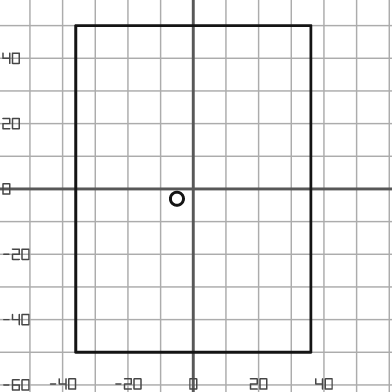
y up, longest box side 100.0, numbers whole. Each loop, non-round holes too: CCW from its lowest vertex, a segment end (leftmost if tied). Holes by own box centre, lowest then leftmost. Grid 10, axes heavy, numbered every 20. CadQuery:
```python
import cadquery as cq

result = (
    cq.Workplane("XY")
    .moveTo(-36.0, -50.0)
    .lineTo(36.0, -50.0)
    .lineTo(36.0, 50.0)
    .lineTo(-36.0, 50.0)
    .close()
    .moveTo(-5.0, -3.0)
    .circle(2.0)
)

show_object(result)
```